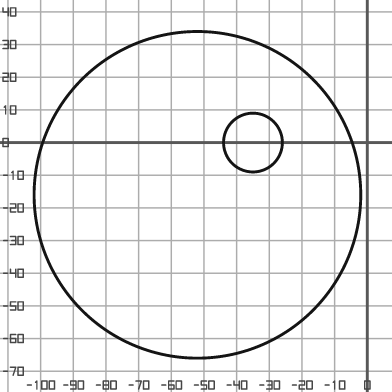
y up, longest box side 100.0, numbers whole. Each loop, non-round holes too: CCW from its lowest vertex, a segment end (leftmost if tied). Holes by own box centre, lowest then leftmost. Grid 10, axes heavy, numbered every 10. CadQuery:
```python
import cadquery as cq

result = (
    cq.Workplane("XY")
    .moveTo(-52.0, -16.0)
    .circle(50.0)
    .moveTo(-35.0, 0.0)
    .circle(9.0)
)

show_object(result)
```